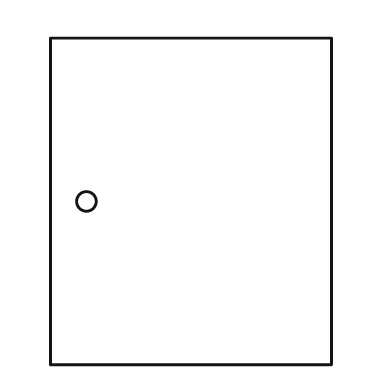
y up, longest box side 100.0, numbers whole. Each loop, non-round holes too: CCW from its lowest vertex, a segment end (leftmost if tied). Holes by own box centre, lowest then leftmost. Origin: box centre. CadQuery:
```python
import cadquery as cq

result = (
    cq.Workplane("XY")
    .moveTo(-43.0, -50.0)
    .lineTo(43.0, -50.0)
    .lineTo(43.0, 50.0)
    .lineTo(-43.0, 50.0)
    .close()
    .moveTo(-32.0, 0.0)
    .circle(3.0)
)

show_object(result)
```